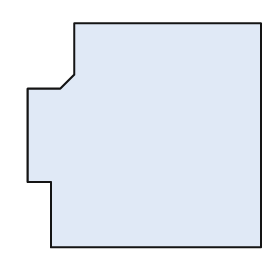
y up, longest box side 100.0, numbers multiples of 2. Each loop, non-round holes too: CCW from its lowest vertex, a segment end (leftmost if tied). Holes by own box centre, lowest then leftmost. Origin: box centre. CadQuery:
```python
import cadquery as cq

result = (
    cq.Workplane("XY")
    .moveTo(-40.0, -48.0)
    .lineTo(50.0, -48.0)
    .lineTo(50.0, 48.0)
    .lineTo(-30.0, 48.0)
    .lineTo(-30.0, 26.0)
    .lineTo(-36.0, 20.0)
    .lineTo(-50.0, 20.0)
    .lineTo(-50.0, -20.0)
    .lineTo(-40.0, -20.0)
    .close()
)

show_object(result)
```